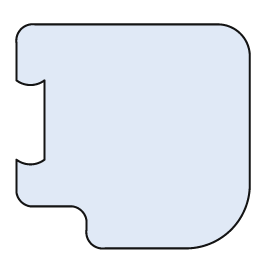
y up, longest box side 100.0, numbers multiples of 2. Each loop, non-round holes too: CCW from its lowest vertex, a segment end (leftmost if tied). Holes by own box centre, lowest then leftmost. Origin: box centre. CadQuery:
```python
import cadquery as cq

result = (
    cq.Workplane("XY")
    .moveTo(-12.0, -48.0)
    .lineTo(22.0, -48.0)
    .threePointArc((42.0, -40.0), (50.0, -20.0))
    .lineTo(50.0, 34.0)
    .threePointArc((46.0, 44.0), (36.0, 48.0))
    .lineTo(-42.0, 48.0)
    .threePointArc((-48.0, 46.0), (-50.0, 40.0))
    .lineTo(-50.0, 24.0)
    .threePointArc((-44.0, 22.0), (-38.0, 24.0))
    .lineTo(-38.0, -10.0)
    .threePointArc((-44.0, -12.0), (-50.0, -10.0))
    .lineTo(-50.0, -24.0)
    .threePointArc((-48.0, -28.0), (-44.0, -30.0))
    .lineTo(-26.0, -30.0)
    .threePointArc((-22.0, -32.0), (-20.0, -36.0))
    .lineTo(-20.0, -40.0)
    .threePointArc((-18.0, -46.0), (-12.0, -48.0))
    .close()
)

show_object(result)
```